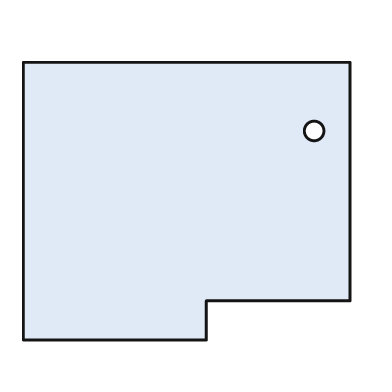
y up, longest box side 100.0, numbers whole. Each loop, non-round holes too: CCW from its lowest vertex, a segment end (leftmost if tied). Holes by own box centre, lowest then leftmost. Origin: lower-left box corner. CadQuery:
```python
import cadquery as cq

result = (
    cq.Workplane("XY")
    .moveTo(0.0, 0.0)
    .lineTo(56.0, 0.0)
    .lineTo(56.0, 12.0)
    .lineTo(100.0, 12.0)
    .lineTo(100.0, 85.0)
    .lineTo(0.0, 85.0)
    .close()
    .moveTo(89.0, 64.0)
    .circle(3.0)
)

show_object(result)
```